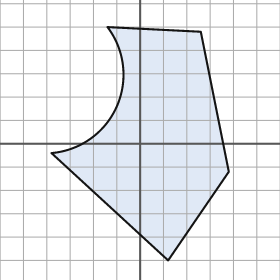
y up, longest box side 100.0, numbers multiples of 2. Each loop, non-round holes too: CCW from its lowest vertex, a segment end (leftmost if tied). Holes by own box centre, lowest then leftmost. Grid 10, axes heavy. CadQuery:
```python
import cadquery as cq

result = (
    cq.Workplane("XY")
    .moveTo(12.0, -50.0)
    .lineTo(38.0, -12.0)
    .lineTo(26.0, 48.0)
    .lineTo(-14.0, 50.0)
    .threePointArc((-10.0, 16.0), (-38.0, -4.0))
    .close()
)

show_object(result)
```